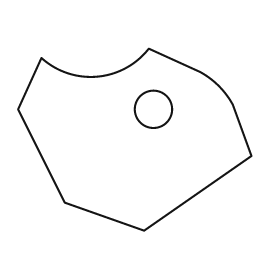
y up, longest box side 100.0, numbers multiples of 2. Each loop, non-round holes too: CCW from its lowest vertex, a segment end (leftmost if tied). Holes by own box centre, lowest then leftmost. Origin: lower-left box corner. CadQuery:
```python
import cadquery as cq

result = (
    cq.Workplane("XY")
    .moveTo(54.0, 0.0)
    .lineTo(100.0, 32.0)
    .lineTo(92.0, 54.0)
    .threePointArc((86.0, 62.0), (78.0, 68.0))
    .lineTo(56.0, 78.0)
    .threePointArc((34.0, 66.0), (10.0, 74.0))
    .lineTo(0.0, 52.0)
    .lineTo(20.0, 12.0)
    .close()
    .moveTo(58.0, 52.0)
    .circle(8.0)
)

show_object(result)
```